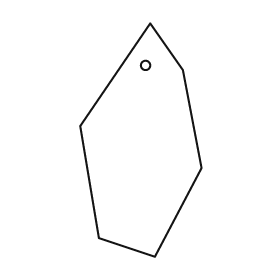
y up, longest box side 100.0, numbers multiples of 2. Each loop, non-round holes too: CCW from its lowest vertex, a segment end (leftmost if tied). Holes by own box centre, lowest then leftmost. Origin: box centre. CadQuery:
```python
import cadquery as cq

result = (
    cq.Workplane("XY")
    .moveTo(6.0, -50.0)
    .lineTo(26.0, -12.0)
    .lineTo(18.0, 30.0)
    .lineTo(4.0, 50.0)
    .lineTo(-26.0, 6.0)
    .lineTo(-18.0, -42.0)
    .close()
    .moveTo(2.0, 32.0)
    .circle(2.0)
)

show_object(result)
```